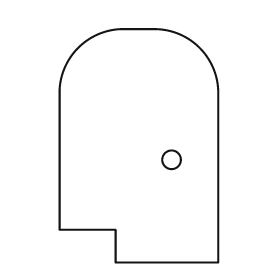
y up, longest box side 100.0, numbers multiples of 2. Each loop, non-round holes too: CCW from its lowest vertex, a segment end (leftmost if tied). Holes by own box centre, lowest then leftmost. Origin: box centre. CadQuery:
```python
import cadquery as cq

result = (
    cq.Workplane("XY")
    .moveTo(-10.0, -50.0)
    .lineTo(34.0, -50.0)
    .lineTo(34.0, 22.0)
    .threePointArc((26.0, 42.0), (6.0, 50.0))
    .lineTo(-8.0, 50.0)
    .threePointArc((-26.0, 42.0), (-34.0, 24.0))
    .lineTo(-34.0, -36.0)
    .lineTo(-10.0, -36.0)
    .close()
    .moveTo(14.0, -6.0)
    .circle(4.0)
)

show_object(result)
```